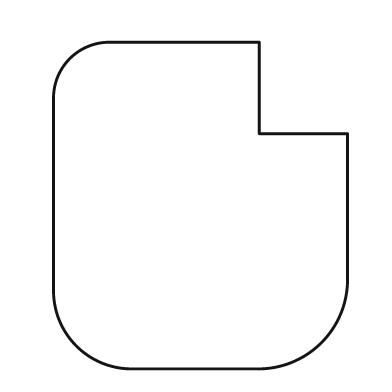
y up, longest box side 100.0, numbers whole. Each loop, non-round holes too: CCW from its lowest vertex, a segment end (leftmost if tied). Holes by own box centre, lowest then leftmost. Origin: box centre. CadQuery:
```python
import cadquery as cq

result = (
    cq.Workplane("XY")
    .moveTo(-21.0, -50.0)
    .lineTo(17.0, -50.0)
    .threePointArc((37.0, -42.0), (45.0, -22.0))
    .lineTo(45.0, 22.0)
    .lineTo(18.0, 22.0)
    .lineTo(18.0, 50.0)
    .lineTo(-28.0, 50.0)
    .threePointArc((-40.0, 45.0), (-45.0, 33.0))
    .lineTo(-45.0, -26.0)
    .threePointArc((-38.0, -43.0), (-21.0, -50.0))
    .close()
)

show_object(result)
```